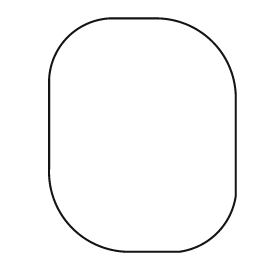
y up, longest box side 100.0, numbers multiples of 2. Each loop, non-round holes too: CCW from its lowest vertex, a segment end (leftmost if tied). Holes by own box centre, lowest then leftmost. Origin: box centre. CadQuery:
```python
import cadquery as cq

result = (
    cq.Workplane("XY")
    .moveTo(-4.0, -50.0)
    .lineTo(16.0, -50.0)
    .threePointArc((32.0, -42.0), (40.0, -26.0))
    .lineTo(40.0, 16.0)
    .threePointArc((30.0, 40.0), (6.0, 50.0))
    .lineTo(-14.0, 50.0)
    .threePointArc((-32.0, 42.0), (-40.0, 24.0))
    .lineTo(-40.0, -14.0)
    .threePointArc((-30.0, -40.0), (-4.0, -50.0))
    .close()
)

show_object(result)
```